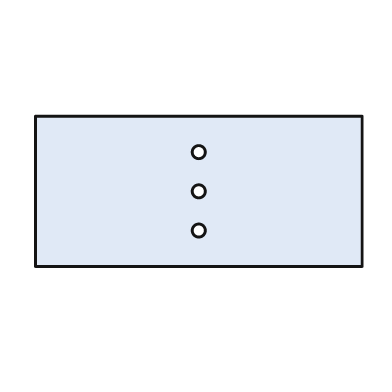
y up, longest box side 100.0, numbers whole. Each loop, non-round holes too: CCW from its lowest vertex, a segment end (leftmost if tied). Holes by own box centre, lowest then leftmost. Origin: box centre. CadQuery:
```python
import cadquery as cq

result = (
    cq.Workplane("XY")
    .moveTo(-50.0, -23.0)
    .lineTo(50.0, -23.0)
    .lineTo(50.0, 23.0)
    .lineTo(-50.0, 23.0)
    .close()
    .moveTo(0.0, -12.0)
    .circle(2.0)
    .moveTo(0.0, 0.0)
    .circle(2.0)
    .moveTo(0.0, 12.0)
    .circle(2.0)
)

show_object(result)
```